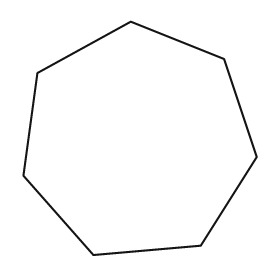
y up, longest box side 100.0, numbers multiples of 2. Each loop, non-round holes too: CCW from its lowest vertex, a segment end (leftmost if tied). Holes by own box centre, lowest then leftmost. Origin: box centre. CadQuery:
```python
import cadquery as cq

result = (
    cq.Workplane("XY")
    .moveTo(-20.0, -50.0)
    .lineTo(26.0, -46.0)
    .lineTo(50.0, -8.0)
    .lineTo(36.0, 34.0)
    .lineTo(-4.0, 50.0)
    .lineTo(-44.0, 28.0)
    .lineTo(-50.0, -16.0)
    .close()
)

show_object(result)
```